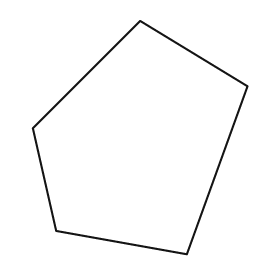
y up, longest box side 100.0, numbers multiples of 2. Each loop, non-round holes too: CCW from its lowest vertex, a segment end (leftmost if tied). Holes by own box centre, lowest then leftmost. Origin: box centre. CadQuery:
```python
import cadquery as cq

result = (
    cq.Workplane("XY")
    .moveTo(20.0, -50.0)
    .lineTo(46.0, 22.0)
    .lineTo(0.0, 50.0)
    .lineTo(-46.0, 4.0)
    .lineTo(-36.0, -40.0)
    .close()
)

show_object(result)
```